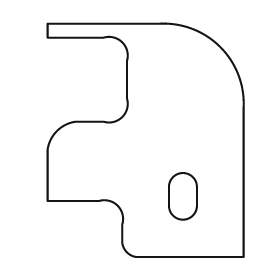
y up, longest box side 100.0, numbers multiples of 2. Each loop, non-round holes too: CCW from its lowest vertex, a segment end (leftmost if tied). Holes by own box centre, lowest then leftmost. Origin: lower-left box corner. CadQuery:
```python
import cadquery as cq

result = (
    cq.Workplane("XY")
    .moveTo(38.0, 0.0)
    .lineTo(84.0, 0.0)
    .lineTo(84.0, 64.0)
    .threePointArc((74.0, 90.0), (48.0, 100.0))
    .lineTo(0.0, 100.0)
    .lineTo(0.0, 94.0)
    .lineTo(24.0, 94.0)
    .threePointArc((32.0, 92.0), (34.0, 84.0))
    .lineTo(34.0, 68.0)
    .threePointArc((32.0, 60.0), (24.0, 58.0))
    .lineTo(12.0, 58.0)
    .threePointArc((4.0, 54.0), (0.0, 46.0))
    .lineTo(0.0, 24.0)
    .lineTo(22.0, 24.0)
    .threePointArc((30.0, 22.0), (32.0, 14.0))
    .lineTo(32.0, 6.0)
    .threePointArc((34.0, 2.0), (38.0, 0.0))
    .close()
    .moveTo(52.0, 22.0)
    .threePointArc((58.0, 16.0), (64.0, 22.0))
    .lineTo(64.0, 30.0)
    .threePointArc((58.0, 36.0), (52.0, 30.0))
    .close()
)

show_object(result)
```